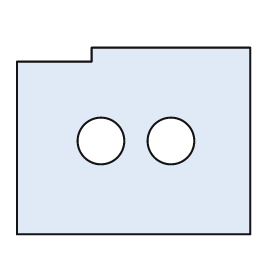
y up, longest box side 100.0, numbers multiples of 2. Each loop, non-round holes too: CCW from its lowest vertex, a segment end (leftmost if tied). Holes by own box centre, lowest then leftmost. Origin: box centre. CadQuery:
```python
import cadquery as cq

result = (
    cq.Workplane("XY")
    .moveTo(-50.0, -40.0)
    .lineTo(50.0, -40.0)
    .lineTo(50.0, 40.0)
    .lineTo(-18.0, 40.0)
    .lineTo(-18.0, 34.0)
    .lineTo(-50.0, 34.0)
    .close()
    .moveTo(-14.0, 0.0)
    .circle(10.0)
    .moveTo(16.0, 0.0)
    .circle(10.0)
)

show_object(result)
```